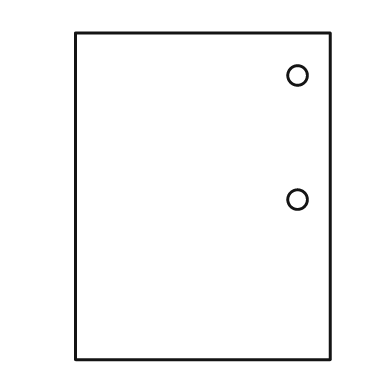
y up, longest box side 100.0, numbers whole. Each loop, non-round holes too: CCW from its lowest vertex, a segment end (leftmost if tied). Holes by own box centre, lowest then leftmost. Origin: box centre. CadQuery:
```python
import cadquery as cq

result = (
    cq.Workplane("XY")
    .moveTo(-39.0, -50.0)
    .lineTo(39.0, -50.0)
    .lineTo(39.0, 50.0)
    .lineTo(-39.0, 50.0)
    .close()
    .moveTo(29.0, -1.0)
    .circle(3.0)
    .moveTo(29.0, 37.0)
    .circle(3.0)
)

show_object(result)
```